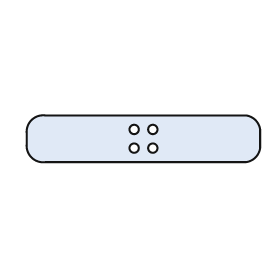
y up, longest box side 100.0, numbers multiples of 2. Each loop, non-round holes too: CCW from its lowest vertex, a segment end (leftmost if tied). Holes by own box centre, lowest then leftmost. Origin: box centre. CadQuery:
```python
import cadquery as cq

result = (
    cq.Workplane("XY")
    .moveTo(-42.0, -10.0)
    .lineTo(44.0, -10.0)
    .threePointArc((48.0, -8.0), (50.0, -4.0))
    .lineTo(50.0, 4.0)
    .threePointArc((48.0, 8.0), (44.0, 10.0))
    .lineTo(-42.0, 10.0)
    .threePointArc((-48.0, 8.0), (-50.0, 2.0))
    .lineTo(-50.0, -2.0)
    .threePointArc((-48.0, -8.0), (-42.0, -10.0))
    .close()
    .moveTo(-4.0, -4.0)
    .circle(2.0)
    .moveTo(4.0, -4.0)
    .circle(2.0)
    .moveTo(-4.0, 4.0)
    .circle(2.0)
    .moveTo(4.0, 4.0)
    .circle(2.0)
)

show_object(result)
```